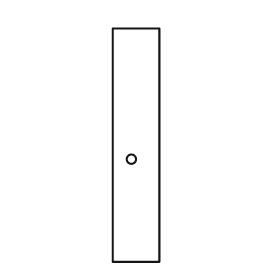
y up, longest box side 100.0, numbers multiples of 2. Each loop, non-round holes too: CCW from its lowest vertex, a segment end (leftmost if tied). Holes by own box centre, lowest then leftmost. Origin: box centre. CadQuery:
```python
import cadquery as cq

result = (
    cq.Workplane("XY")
    .moveTo(-10.0, -50.0)
    .lineTo(10.0, -50.0)
    .lineTo(10.0, 50.0)
    .lineTo(-10.0, 50.0)
    .close()
    .moveTo(-2.0, -6.0)
    .circle(2.0)
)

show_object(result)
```